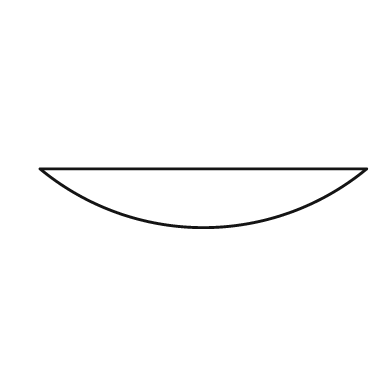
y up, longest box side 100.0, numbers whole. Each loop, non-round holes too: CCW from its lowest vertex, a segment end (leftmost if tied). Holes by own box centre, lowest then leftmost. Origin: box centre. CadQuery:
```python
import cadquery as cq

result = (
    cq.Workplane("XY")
    .moveTo(-50.0, 9.0)
    .threePointArc((0.0, -9.0), (50.0, 9.0))
    .close()
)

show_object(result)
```